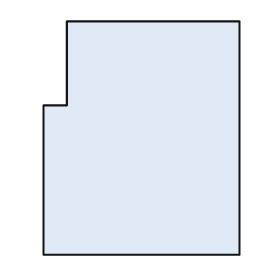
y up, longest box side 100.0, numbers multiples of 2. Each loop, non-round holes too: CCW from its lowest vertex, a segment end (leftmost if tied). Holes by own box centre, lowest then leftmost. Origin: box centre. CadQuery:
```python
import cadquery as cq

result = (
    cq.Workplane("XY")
    .moveTo(-42.0, -50.0)
    .lineTo(42.0, -50.0)
    .lineTo(42.0, 50.0)
    .lineTo(-32.0, 50.0)
    .lineTo(-32.0, 14.0)
    .lineTo(-42.0, 14.0)
    .close()
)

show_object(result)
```